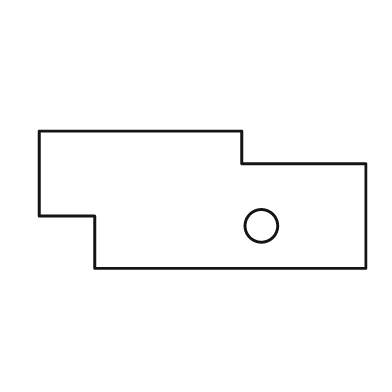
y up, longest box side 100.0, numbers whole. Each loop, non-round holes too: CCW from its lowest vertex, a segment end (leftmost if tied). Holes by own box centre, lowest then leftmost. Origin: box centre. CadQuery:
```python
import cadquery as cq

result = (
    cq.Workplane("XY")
    .moveTo(-33.0, -21.0)
    .lineTo(50.0, -21.0)
    .lineTo(50.0, 11.0)
    .lineTo(12.0, 11.0)
    .lineTo(12.0, 21.0)
    .lineTo(-50.0, 21.0)
    .lineTo(-50.0, -5.0)
    .lineTo(-33.0, -5.0)
    .close()
    .moveTo(18.0, -8.0)
    .circle(5.0)
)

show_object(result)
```